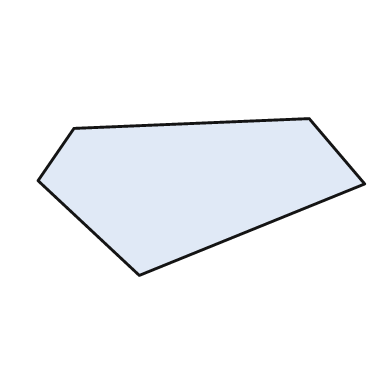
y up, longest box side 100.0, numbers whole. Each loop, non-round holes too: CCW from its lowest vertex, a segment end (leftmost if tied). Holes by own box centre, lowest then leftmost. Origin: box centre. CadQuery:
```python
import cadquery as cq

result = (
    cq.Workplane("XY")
    .moveTo(-19.0, -24.0)
    .lineTo(50.0, 4.0)
    .lineTo(33.0, 24.0)
    .lineTo(-39.0, 21.0)
    .lineTo(-50.0, 5.0)
    .close()
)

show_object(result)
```